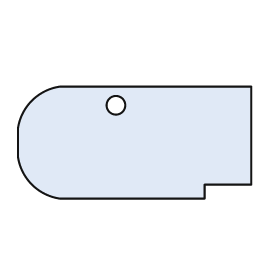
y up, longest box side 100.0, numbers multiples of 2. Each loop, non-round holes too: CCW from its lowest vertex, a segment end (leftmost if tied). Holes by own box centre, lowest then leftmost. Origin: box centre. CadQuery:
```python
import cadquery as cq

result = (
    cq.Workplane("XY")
    .moveTo(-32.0, -24.0)
    .lineTo(30.0, -24.0)
    .lineTo(30.0, -18.0)
    .lineTo(50.0, -18.0)
    .lineTo(50.0, 24.0)
    .lineTo(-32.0, 24.0)
    .threePointArc((-44.0, 18.0), (-50.0, 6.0))
    .lineTo(-50.0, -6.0)
    .threePointArc((-44.0, -18.0), (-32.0, -24.0))
    .close()
    .moveTo(-8.0, 16.0)
    .circle(4.0)
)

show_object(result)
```